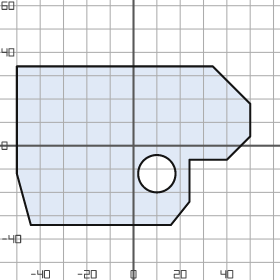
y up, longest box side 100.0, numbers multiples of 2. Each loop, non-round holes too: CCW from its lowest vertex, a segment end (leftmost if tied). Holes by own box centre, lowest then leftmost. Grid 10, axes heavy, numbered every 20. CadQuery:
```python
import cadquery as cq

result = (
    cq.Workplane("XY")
    .moveTo(-44.0, -34.0)
    .lineTo(16.0, -34.0)
    .lineTo(24.0, -24.0)
    .lineTo(24.0, -6.0)
    .lineTo(40.0, -6.0)
    .lineTo(50.0, 4.0)
    .lineTo(50.0, 18.0)
    .lineTo(34.0, 34.0)
    .lineTo(-50.0, 34.0)
    .lineTo(-50.0, -12.0)
    .close()
    .moveTo(10.0, -12.0)
    .circle(8.0)
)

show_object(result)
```